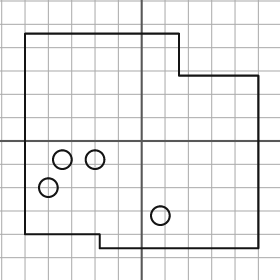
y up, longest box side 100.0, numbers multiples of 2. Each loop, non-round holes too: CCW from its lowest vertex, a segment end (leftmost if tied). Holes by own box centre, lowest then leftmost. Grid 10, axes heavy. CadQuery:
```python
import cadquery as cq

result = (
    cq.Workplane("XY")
    .moveTo(-18.0, -46.0)
    .lineTo(50.0, -46.0)
    .lineTo(50.0, 28.0)
    .lineTo(16.0, 28.0)
    .lineTo(16.0, 46.0)
    .lineTo(-50.0, 46.0)
    .lineTo(-50.0, -40.0)
    .lineTo(-18.0, -40.0)
    .close()
    .moveTo(8.0, -32.0)
    .circle(4.0)
    .moveTo(-40.0, -20.0)
    .circle(4.0)
    .moveTo(-34.0, -8.0)
    .circle(4.0)
    .moveTo(-20.0, -8.0)
    .circle(4.0)
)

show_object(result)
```